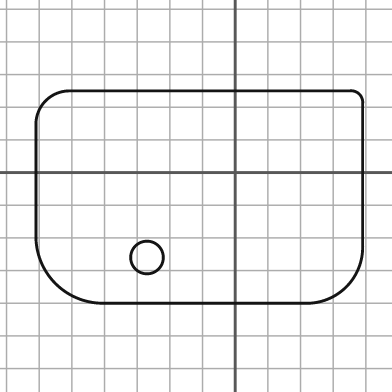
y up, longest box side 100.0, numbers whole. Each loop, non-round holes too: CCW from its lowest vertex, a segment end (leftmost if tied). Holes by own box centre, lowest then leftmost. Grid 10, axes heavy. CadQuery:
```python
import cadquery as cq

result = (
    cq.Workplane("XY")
    .moveTo(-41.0, -40.0)
    .lineTo(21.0, -40.0)
    .threePointArc((34.0, -35.0), (39.0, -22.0))
    .lineTo(39.0, 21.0)
    .threePointArc((38.0, 24.0), (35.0, 25.0))
    .lineTo(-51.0, 25.0)
    .threePointArc((-58.0, 22.0), (-61.0, 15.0))
    .lineTo(-61.0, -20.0)
    .threePointArc((-55.0, -34.0), (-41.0, -40.0))
    .close()
    .moveTo(-27.0, -26.0)
    .circle(5.0)
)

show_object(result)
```